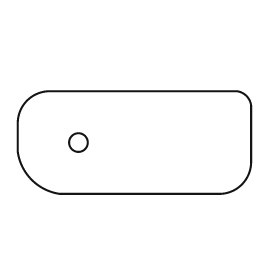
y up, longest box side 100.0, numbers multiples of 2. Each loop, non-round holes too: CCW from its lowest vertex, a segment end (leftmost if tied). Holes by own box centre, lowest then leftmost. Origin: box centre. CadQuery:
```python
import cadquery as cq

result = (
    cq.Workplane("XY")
    .moveTo(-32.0, -22.0)
    .lineTo(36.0, -22.0)
    .threePointArc((46.0, -18.0), (50.0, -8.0))
    .lineTo(50.0, 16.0)
    .threePointArc((48.0, 20.0), (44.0, 22.0))
    .lineTo(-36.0, 22.0)
    .threePointArc((-46.0, 18.0), (-50.0, 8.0))
    .lineTo(-50.0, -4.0)
    .threePointArc((-44.0, -16.0), (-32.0, -22.0))
    .close()
    .moveTo(-24.0, 0.0)
    .circle(4.0)
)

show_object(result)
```